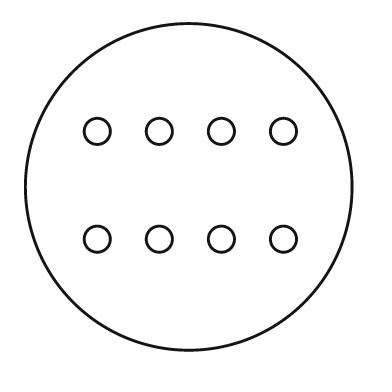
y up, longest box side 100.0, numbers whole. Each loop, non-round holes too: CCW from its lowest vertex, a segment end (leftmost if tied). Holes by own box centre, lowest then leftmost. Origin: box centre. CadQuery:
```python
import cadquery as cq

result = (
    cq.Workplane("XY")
    .moveTo(0.0, 0.0)
    .circle(50.0)
    .moveTo(-28.0, -16.0)
    .circle(4.0)
    .moveTo(-9.0, -16.0)
    .circle(4.0)
    .moveTo(10.0, -16.0)
    .circle(4.0)
    .moveTo(29.0, -16.0)
    .circle(4.0)
    .moveTo(-28.0, 17.0)
    .circle(4.0)
    .moveTo(-9.0, 17.0)
    .circle(4.0)
    .moveTo(10.0, 17.0)
    .circle(4.0)
    .moveTo(29.0, 17.0)
    .circle(4.0)
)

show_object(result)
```